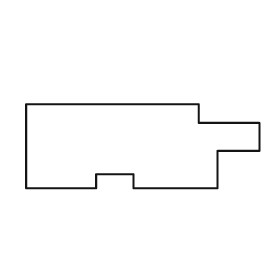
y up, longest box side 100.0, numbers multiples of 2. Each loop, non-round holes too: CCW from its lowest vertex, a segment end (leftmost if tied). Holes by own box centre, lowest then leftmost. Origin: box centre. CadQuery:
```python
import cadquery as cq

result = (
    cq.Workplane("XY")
    .moveTo(-50.0, -18.0)
    .lineTo(-20.0, -18.0)
    .lineTo(-20.0, -12.0)
    .lineTo(-4.0, -12.0)
    .lineTo(-4.0, -18.0)
    .lineTo(32.0, -18.0)
    .lineTo(32.0, -2.0)
    .lineTo(50.0, -2.0)
    .lineTo(50.0, 10.0)
    .lineTo(24.0, 10.0)
    .lineTo(24.0, 18.0)
    .lineTo(-50.0, 18.0)
    .close()
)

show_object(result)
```